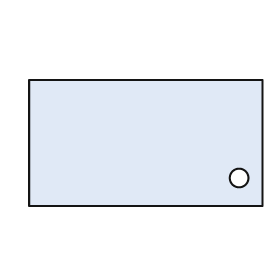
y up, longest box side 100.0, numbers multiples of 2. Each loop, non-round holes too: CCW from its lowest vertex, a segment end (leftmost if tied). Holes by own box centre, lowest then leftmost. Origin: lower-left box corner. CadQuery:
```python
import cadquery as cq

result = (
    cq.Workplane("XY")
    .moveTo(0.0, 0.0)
    .lineTo(100.0, 0.0)
    .lineTo(100.0, 54.0)
    .lineTo(0.0, 54.0)
    .close()
    .moveTo(90.0, 12.0)
    .circle(4.0)
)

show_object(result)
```